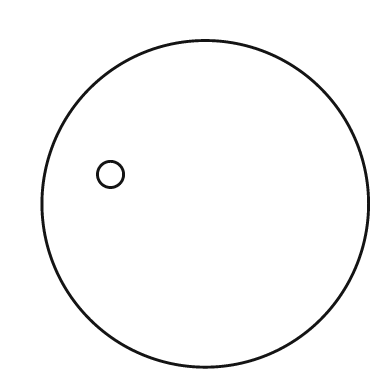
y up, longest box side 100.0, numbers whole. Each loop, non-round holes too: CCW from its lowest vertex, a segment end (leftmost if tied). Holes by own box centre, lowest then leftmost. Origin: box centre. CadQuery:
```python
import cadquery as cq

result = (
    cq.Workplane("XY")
    .moveTo(0.0, 0.0)
    .circle(50.0)
    .moveTo(-29.0, 9.0)
    .circle(4.0)
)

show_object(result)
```